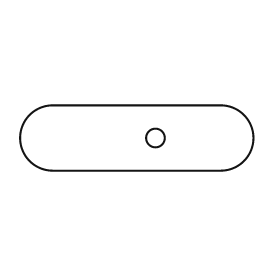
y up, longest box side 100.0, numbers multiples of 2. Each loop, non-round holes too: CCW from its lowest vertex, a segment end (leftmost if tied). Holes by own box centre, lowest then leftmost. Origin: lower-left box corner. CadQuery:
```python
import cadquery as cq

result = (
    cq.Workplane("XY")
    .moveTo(14.0, 0.0)
    .lineTo(86.0, 0.0)
    .threePointArc((100.0, 14.0), (86.0, 28.0))
    .lineTo(14.0, 28.0)
    .threePointArc((0.0, 14.0), (14.0, 0.0))
    .close()
    .moveTo(58.0, 14.0)
    .circle(4.0)
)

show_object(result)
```